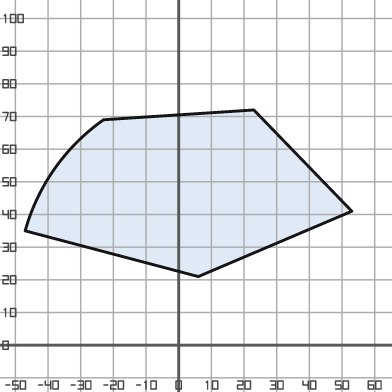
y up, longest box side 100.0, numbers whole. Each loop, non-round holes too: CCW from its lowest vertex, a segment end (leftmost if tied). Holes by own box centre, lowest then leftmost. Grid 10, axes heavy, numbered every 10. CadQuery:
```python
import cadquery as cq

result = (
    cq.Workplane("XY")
    .moveTo(6.0, 21.0)
    .lineTo(53.0, 41.0)
    .lineTo(23.0, 72.0)
    .lineTo(-23.0, 69.0)
    .threePointArc((-38.0, 54.0), (-47.0, 35.0))
    .close()
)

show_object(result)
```